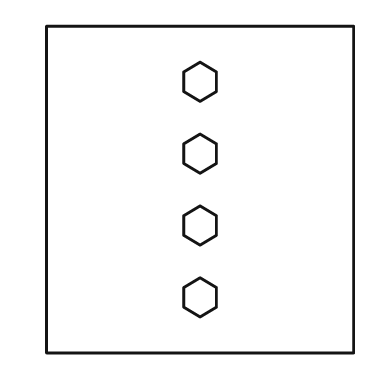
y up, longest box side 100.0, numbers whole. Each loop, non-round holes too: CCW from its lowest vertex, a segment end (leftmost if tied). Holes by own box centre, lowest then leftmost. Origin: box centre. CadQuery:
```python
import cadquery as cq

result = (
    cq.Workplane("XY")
    .moveTo(-47.0, -50.0)
    .lineTo(47.0, -50.0)
    .lineTo(47.0, 50.0)
    .lineTo(-47.0, 50.0)
    .close()
    .moveTo(0.0, -39.0)
    .lineTo(5.0, -36.0)
    .lineTo(5.0, -30.0)
    .lineTo(0.0, -27.0)
    .lineTo(-5.0, -30.0)
    .lineTo(-5.0, -36.0)
    .close()
    .moveTo(0.0, -17.0)
    .lineTo(5.0, -14.0)
    .lineTo(5.0, -8.0)
    .lineTo(0.0, -5.0)
    .lineTo(-5.0, -8.0)
    .lineTo(-5.0, -14.0)
    .close()
    .moveTo(0.0, 5.0)
    .lineTo(5.0, 8.0)
    .lineTo(5.0, 14.0)
    .lineTo(0.0, 17.0)
    .lineTo(-5.0, 14.0)
    .lineTo(-5.0, 8.0)
    .close()
    .moveTo(0.0, 27.0)
    .lineTo(5.0, 30.0)
    .lineTo(5.0, 36.0)
    .lineTo(0.0, 39.0)
    .lineTo(-5.0, 36.0)
    .lineTo(-5.0, 30.0)
    .close()
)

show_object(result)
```